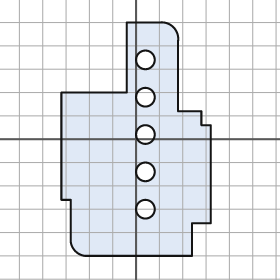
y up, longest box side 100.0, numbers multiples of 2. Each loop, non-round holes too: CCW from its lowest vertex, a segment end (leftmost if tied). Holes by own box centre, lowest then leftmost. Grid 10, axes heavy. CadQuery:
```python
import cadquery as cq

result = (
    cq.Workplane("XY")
    .moveTo(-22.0, -50.0)
    .lineTo(24.0, -50.0)
    .lineTo(24.0, -36.0)
    .lineTo(32.0, -36.0)
    .lineTo(32.0, 6.0)
    .lineTo(28.0, 6.0)
    .lineTo(28.0, 12.0)
    .lineTo(18.0, 12.0)
    .lineTo(18.0, 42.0)
    .threePointArc((16.0, 48.0), (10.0, 50.0))
    .lineTo(-4.0, 50.0)
    .lineTo(-4.0, 20.0)
    .lineTo(-32.0, 20.0)
    .lineTo(-32.0, -26.0)
    .lineTo(-28.0, -26.0)
    .lineTo(-28.0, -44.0)
    .threePointArc((-26.0, -48.0), (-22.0, -50.0))
    .close()
    .moveTo(4.0, -30.0)
    .circle(4.0)
    .moveTo(4.0, -14.0)
    .circle(4.0)
    .moveTo(4.0, 2.0)
    .circle(4.0)
    .moveTo(4.0, 18.0)
    .circle(4.0)
    .moveTo(4.0, 34.0)
    .circle(4.0)
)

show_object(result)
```